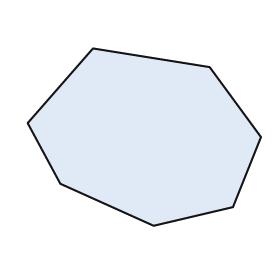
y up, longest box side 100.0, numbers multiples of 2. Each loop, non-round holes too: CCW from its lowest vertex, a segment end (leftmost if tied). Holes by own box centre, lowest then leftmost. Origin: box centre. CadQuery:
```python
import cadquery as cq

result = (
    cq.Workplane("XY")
    .moveTo(4.0, -38.0)
    .lineTo(38.0, -30.0)
    .lineTo(50.0, 0.0)
    .lineTo(28.0, 30.0)
    .lineTo(-22.0, 38.0)
    .lineTo(-50.0, 6.0)
    .lineTo(-36.0, -20.0)
    .close()
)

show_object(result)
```